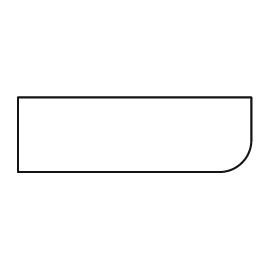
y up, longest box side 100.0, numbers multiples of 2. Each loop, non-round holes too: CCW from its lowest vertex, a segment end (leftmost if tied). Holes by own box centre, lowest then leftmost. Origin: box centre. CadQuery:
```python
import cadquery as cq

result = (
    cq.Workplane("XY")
    .moveTo(-50.0, -16.0)
    .lineTo(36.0, -16.0)
    .threePointArc((46.0, -12.0), (50.0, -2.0))
    .lineTo(50.0, 16.0)
    .lineTo(-50.0, 16.0)
    .close()
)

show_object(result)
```